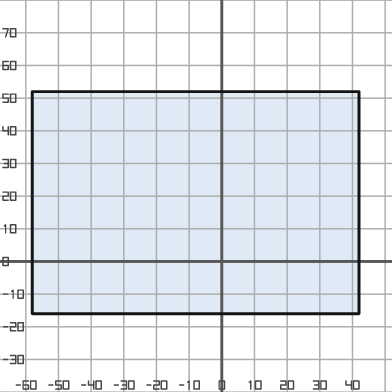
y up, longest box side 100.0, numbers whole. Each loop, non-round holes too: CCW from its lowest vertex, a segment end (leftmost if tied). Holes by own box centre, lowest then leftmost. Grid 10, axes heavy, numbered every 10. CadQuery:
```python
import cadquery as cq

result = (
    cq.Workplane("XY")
    .moveTo(-58.0, -16.0)
    .lineTo(42.0, -16.0)
    .lineTo(42.0, 52.0)
    .lineTo(-58.0, 52.0)
    .close()
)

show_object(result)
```